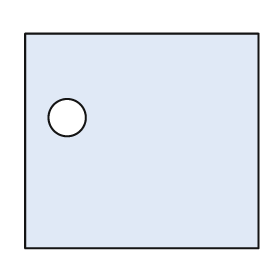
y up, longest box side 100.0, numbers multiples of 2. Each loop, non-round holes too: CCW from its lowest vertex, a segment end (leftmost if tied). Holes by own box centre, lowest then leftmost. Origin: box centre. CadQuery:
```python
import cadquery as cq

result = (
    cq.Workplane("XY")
    .moveTo(-50.0, -46.0)
    .lineTo(50.0, -46.0)
    .lineTo(50.0, 46.0)
    .lineTo(-50.0, 46.0)
    .close()
    .moveTo(-32.0, 10.0)
    .circle(8.0)
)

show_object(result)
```